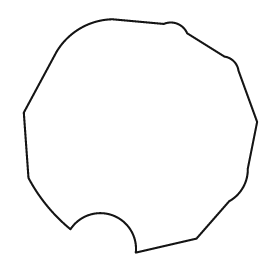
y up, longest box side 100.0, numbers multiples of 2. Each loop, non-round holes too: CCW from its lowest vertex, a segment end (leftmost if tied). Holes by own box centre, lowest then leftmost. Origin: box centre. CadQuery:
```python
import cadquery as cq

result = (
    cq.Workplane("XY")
    .moveTo(-2.0, -50.0)
    .lineTo(24.0, -44.0)
    .lineTo(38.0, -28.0)
    .threePointArc((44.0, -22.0), (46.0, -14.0))
    .lineTo(50.0, 6.0)
    .lineTo(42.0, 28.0)
    .threePointArc((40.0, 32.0), (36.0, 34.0))
    .lineTo(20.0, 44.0)
    .threePointArc((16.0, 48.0), (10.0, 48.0))
    .lineTo(-12.0, 50.0)
    .threePointArc((-26.0, 46.0), (-36.0, 36.0))
    .lineTo(-50.0, 10.0)
    .lineTo(-48.0, -18.0)
    .threePointArc((-40.0, -30.0), (-30.0, -40.0))
    .threePointArc((-12.0, -34.0), (-2.0, -50.0))
    .close()
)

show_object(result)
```